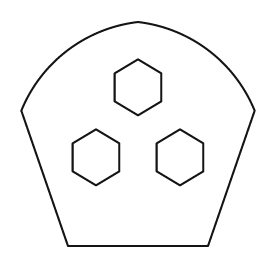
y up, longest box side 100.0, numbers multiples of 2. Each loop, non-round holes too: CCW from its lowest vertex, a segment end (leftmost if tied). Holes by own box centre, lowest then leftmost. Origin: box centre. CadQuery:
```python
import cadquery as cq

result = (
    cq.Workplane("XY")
    .moveTo(-30.0, -48.0)
    .lineTo(30.0, -48.0)
    .lineTo(50.0, 10.0)
    .threePointArc((30.0, 36.0), (0.0, 48.0))
    .threePointArc((-30.0, 36.0), (-50.0, 10.0))
    .close()
    .moveTo(-18.0, -22.0)
    .lineTo(-8.0, -16.0)
    .lineTo(-8.0, -4.0)
    .lineTo(-18.0, 2.0)
    .lineTo(-28.0, -4.0)
    .lineTo(-28.0, -16.0)
    .close()
    .moveTo(18.0, -22.0)
    .lineTo(28.0, -16.0)
    .lineTo(28.0, -4.0)
    .lineTo(18.0, 2.0)
    .lineTo(8.0, -4.0)
    .lineTo(8.0, -16.0)
    .close()
    .moveTo(0.0, 8.0)
    .lineTo(10.0, 14.0)
    .lineTo(10.0, 26.0)
    .lineTo(0.0, 32.0)
    .lineTo(-10.0, 26.0)
    .lineTo(-10.0, 14.0)
    .close()
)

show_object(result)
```